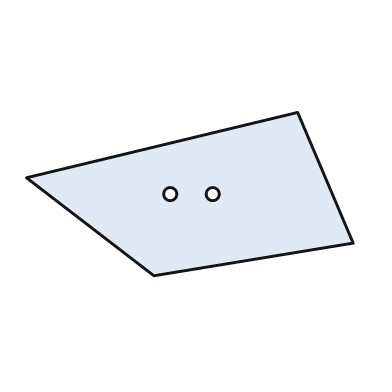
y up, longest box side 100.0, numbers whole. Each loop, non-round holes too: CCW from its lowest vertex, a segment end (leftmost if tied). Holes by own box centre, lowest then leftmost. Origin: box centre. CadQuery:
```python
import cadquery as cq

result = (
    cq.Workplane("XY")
    .moveTo(-11.0, -25.0)
    .lineTo(50.0, -15.0)
    .lineTo(33.0, 25.0)
    .lineTo(-50.0, 5.0)
    .close()
    .moveTo(-6.0, 0.0)
    .circle(2.0)
    .moveTo(7.0, 0.0)
    .circle(2.0)
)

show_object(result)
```